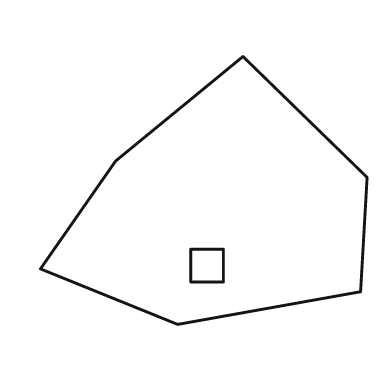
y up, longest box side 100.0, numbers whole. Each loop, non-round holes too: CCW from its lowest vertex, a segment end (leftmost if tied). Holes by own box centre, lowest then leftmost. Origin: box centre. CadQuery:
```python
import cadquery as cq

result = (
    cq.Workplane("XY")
    .moveTo(-8.0, -41.0)
    .lineTo(48.0, -31.0)
    .lineTo(50.0, 4.0)
    .lineTo(12.0, 41.0)
    .lineTo(-27.0, 9.0)
    .lineTo(-50.0, -24.0)
    .close()
    .moveTo(-4.0, -28.0)
    .lineTo(6.0, -28.0)
    .lineTo(6.0, -18.0)
    .lineTo(-4.0, -18.0)
    .close()
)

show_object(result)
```